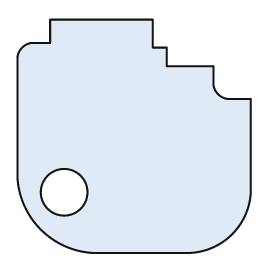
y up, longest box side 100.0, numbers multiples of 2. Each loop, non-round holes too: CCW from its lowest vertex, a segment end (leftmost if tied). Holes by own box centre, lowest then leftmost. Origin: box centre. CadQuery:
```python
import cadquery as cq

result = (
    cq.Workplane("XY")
    .moveTo(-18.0, -50.0)
    .lineTo(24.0, -50.0)
    .threePointArc((42.0, -42.0), (50.0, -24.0))
    .lineTo(50.0, 16.0)
    .lineTo(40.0, 16.0)
    .threePointArc((36.0, 18.0), (34.0, 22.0))
    .lineTo(34.0, 30.0)
    .lineTo(14.0, 30.0)
    .lineTo(14.0, 38.0)
    .lineTo(8.0, 38.0)
    .lineTo(8.0, 50.0)
    .lineTo(-36.0, 50.0)
    .lineTo(-36.0, 40.0)
    .lineTo(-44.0, 40.0)
    .threePointArc((-48.0, 38.0), (-50.0, 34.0))
    .lineTo(-50.0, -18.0)
    .threePointArc((-40.0, -40.0), (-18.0, -50.0))
    .close()
    .moveTo(-30.0, -24.0)
    .circle(10.0)
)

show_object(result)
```